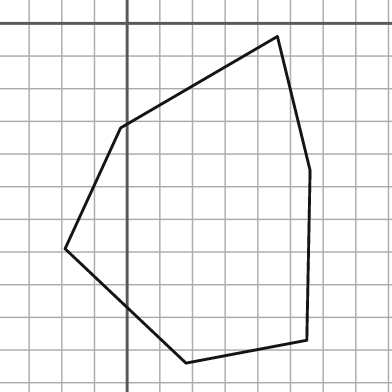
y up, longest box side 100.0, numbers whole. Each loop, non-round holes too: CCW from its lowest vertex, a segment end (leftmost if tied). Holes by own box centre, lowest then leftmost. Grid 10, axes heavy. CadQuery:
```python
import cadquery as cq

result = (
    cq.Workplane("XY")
    .moveTo(18.0, -104.0)
    .lineTo(55.0, -97.0)
    .lineTo(56.0, -45.0)
    .lineTo(46.0, -4.0)
    .lineTo(-2.0, -32.0)
    .lineTo(-19.0, -69.0)
    .close()
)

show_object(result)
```